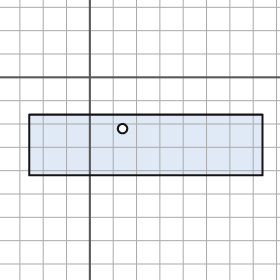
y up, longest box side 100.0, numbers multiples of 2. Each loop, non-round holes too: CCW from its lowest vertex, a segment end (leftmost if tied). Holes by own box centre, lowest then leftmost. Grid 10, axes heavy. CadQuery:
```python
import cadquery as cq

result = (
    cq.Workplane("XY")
    .moveTo(-26.0, -42.0)
    .lineTo(74.0, -42.0)
    .lineTo(74.0, -16.0)
    .lineTo(-26.0, -16.0)
    .close()
    .moveTo(14.0, -22.0)
    .circle(2.0)
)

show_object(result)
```